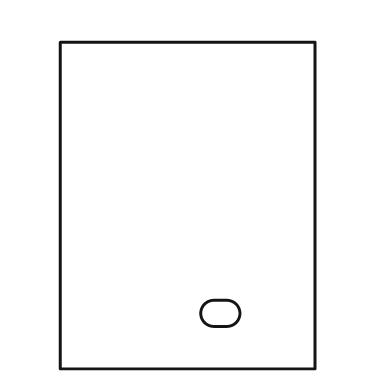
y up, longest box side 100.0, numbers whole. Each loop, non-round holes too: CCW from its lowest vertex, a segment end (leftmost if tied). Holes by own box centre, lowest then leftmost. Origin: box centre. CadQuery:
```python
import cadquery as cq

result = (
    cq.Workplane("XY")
    .moveTo(-39.0, -50.0)
    .lineTo(39.0, -50.0)
    .lineTo(39.0, 50.0)
    .lineTo(-39.0, 50.0)
    .close()
    .moveTo(8.0, -37.0)
    .lineTo(12.0, -37.0)
    .threePointArc((16.0, -33.0), (12.0, -29.0))
    .lineTo(8.0, -29.0)
    .threePointArc((4.0, -33.0), (8.0, -37.0))
    .close()
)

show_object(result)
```